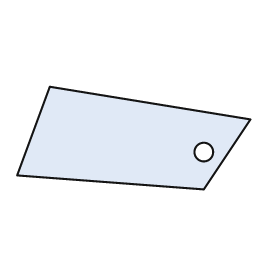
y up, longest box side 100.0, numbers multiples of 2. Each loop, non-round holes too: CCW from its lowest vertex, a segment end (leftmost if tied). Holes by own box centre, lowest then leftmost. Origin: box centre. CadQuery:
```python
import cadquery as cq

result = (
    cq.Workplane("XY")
    .moveTo(30.0, -22.0)
    .lineTo(50.0, 8.0)
    .lineTo(-36.0, 22.0)
    .lineTo(-50.0, -16.0)
    .close()
    .moveTo(30.0, -6.0)
    .circle(4.0)
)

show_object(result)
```